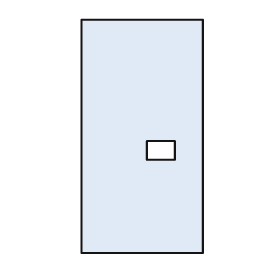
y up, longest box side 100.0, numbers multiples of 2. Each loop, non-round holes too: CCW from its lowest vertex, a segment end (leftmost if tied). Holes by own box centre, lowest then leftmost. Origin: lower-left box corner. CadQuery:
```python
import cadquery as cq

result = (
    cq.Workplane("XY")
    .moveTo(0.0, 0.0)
    .lineTo(52.0, 0.0)
    .lineTo(52.0, 100.0)
    .lineTo(0.0, 100.0)
    .close()
    .moveTo(28.0, 40.0)
    .lineTo(40.0, 40.0)
    .lineTo(40.0, 48.0)
    .lineTo(28.0, 48.0)
    .close()
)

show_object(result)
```